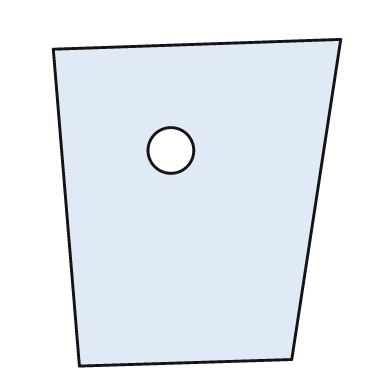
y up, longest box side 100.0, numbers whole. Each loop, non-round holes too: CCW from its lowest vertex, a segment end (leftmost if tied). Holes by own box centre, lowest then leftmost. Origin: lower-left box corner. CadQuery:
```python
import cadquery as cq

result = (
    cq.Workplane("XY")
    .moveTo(8.0, 0.0)
    .lineTo(73.0, 2.0)
    .lineTo(88.0, 100.0)
    .lineTo(0.0, 97.0)
    .close()
    .moveTo(36.0, 66.0)
    .circle(7.0)
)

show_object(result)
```